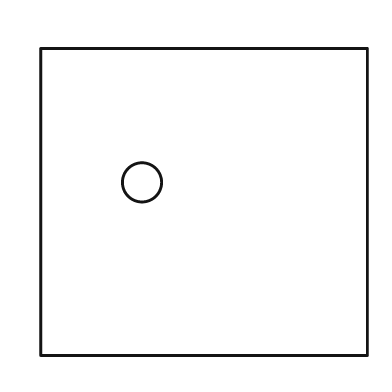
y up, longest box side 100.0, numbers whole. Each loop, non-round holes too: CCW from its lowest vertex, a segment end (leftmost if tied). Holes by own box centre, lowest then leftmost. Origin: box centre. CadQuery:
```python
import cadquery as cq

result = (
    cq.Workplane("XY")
    .moveTo(-50.0, -47.0)
    .lineTo(50.0, -47.0)
    .lineTo(50.0, 47.0)
    .lineTo(-50.0, 47.0)
    .close()
    .moveTo(-19.0, 6.0)
    .circle(6.0)
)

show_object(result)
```